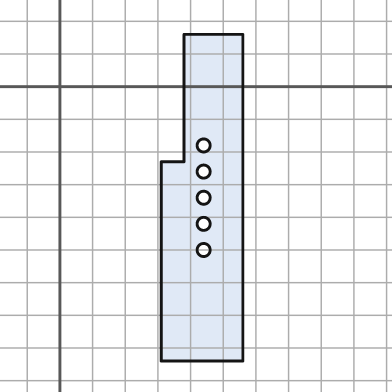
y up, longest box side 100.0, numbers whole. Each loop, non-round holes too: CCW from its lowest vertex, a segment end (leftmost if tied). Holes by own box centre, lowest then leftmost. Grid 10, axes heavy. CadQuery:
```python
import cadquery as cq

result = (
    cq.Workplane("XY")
    .moveTo(31.0, -84.0)
    .lineTo(56.0, -84.0)
    .lineTo(56.0, 16.0)
    .lineTo(38.0, 16.0)
    .lineTo(38.0, -23.0)
    .lineTo(31.0, -23.0)
    .close()
    .moveTo(44.0, -50.0)
    .circle(2.0)
    .moveTo(44.0, -42.0)
    .circle(2.0)
    .moveTo(44.0, -34.0)
    .circle(2.0)
    .moveTo(44.0, -26.0)
    .circle(2.0)
    .moveTo(44.0, -18.0)
    .circle(2.0)
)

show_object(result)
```